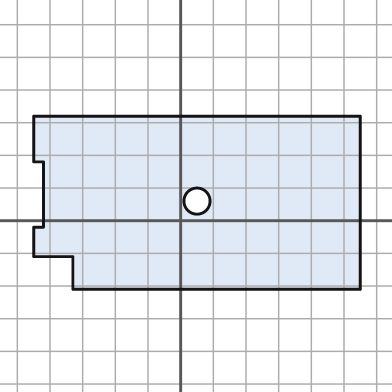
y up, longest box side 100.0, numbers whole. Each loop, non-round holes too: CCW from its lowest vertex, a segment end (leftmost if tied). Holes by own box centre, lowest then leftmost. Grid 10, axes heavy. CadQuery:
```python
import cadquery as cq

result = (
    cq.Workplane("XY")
    .moveTo(-33.0, -21.0)
    .lineTo(55.0, -21.0)
    .lineTo(55.0, 32.0)
    .lineTo(-45.0, 32.0)
    .lineTo(-45.0, 18.0)
    .lineTo(-42.0, 18.0)
    .lineTo(-42.0, -2.0)
    .lineTo(-45.0, -2.0)
    .lineTo(-45.0, -11.0)
    .lineTo(-33.0, -11.0)
    .close()
    .moveTo(5.0, 6.0)
    .circle(4.0)
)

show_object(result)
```